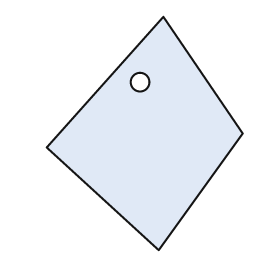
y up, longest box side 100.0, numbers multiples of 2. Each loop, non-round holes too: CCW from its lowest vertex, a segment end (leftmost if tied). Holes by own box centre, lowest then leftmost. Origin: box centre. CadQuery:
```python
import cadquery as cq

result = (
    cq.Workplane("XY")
    .moveTo(6.0, -50.0)
    .lineTo(42.0, 0.0)
    .lineTo(8.0, 50.0)
    .lineTo(-42.0, -6.0)
    .close()
    .moveTo(-2.0, 22.0)
    .circle(4.0)
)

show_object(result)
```